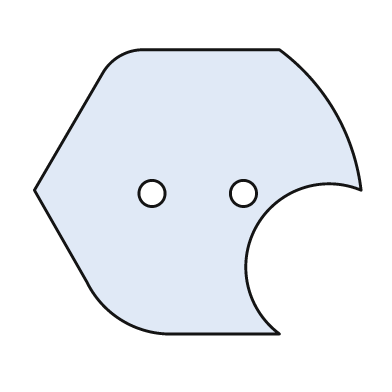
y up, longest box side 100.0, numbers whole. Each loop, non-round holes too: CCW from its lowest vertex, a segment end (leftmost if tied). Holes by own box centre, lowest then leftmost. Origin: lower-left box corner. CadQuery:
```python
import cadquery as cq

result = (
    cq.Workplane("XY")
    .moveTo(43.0, 0.0)
    .lineTo(75.0, 0.0)
    .threePointArc((68.0, 33.0), (100.0, 44.0))
    .threePointArc((92.0, 68.0), (75.0, 87.0))
    .lineTo(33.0, 87.0)
    .threePointArc((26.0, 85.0), (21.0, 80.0))
    .lineTo(0.0, 44.0)
    .lineTo(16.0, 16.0)
    .threePointArc((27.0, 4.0), (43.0, 0.0))
    .close()
    .moveTo(36.0, 43.0)
    .circle(4.0)
    .moveTo(64.0, 43.0)
    .circle(4.0)
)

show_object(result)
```